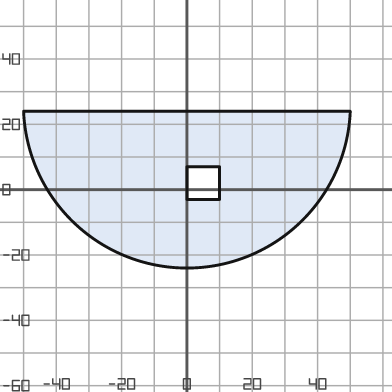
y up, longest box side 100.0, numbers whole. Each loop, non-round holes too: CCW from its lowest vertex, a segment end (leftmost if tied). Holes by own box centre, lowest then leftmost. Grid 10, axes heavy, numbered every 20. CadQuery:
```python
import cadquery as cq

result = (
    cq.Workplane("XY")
    .moveTo(-50.0, 24.0)
    .threePointArc((0.0, -24.0), (50.0, 24.0))
    .close()
    .moveTo(0.0, -3.0)
    .lineTo(10.0, -3.0)
    .lineTo(10.0, 7.0)
    .lineTo(0.0, 7.0)
    .close()
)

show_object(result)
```